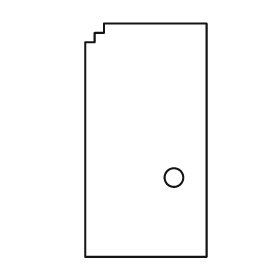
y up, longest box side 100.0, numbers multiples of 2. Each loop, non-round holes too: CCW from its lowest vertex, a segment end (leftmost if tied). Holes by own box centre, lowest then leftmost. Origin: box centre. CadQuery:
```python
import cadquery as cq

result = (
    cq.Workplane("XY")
    .moveTo(-26.0, -50.0)
    .lineTo(26.0, -50.0)
    .lineTo(26.0, 50.0)
    .lineTo(-18.0, 50.0)
    .lineTo(-18.0, 46.0)
    .lineTo(-22.0, 46.0)
    .lineTo(-22.0, 42.0)
    .lineTo(-26.0, 42.0)
    .close()
    .moveTo(12.0, -16.0)
    .circle(4.0)
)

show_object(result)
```